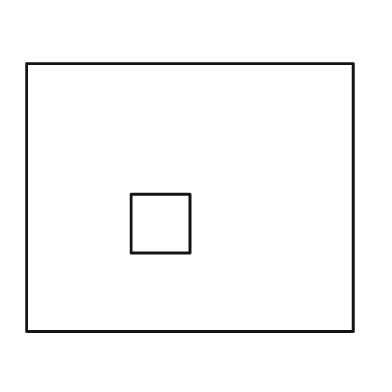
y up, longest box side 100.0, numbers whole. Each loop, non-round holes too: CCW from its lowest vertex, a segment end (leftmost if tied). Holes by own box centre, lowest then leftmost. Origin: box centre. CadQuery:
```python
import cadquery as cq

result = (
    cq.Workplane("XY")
    .moveTo(-50.0, -41.0)
    .lineTo(50.0, -41.0)
    .lineTo(50.0, 41.0)
    .lineTo(-50.0, 41.0)
    .close()
    .moveTo(-18.0, -17.0)
    .lineTo(0.0, -17.0)
    .lineTo(0.0, 1.0)
    .lineTo(-18.0, 1.0)
    .close()
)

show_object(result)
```